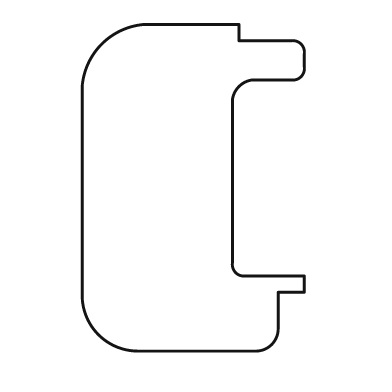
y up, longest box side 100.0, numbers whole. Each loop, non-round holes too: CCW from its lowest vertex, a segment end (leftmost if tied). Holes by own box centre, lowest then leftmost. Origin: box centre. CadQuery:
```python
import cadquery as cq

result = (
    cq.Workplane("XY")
    .moveTo(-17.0, -50.0)
    .lineTo(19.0, -50.0)
    .threePointArc((24.0, -48.0), (26.0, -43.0))
    .lineTo(26.0, -32.0)
    .lineTo(34.0, -32.0)
    .lineTo(34.0, -27.0)
    .lineTo(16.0, -27.0)
    .threePointArc((13.0, -26.0), (12.0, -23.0))
    .lineTo(12.0, 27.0)
    .threePointArc((14.0, 31.0), (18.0, 33.0))
    .lineTo(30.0, 33.0)
    .threePointArc((33.0, 34.0), (34.0, 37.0))
    .lineTo(34.0, 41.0)
    .threePointArc((33.0, 44.0), (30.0, 45.0))
    .lineTo(14.0, 45.0)
    .lineTo(14.0, 50.0)
    .lineTo(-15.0, 50.0)
    .threePointArc((-28.0, 44.0), (-34.0, 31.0))
    .lineTo(-34.0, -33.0)
    .threePointArc((-29.0, -45.0), (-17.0, -50.0))
    .close()
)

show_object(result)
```